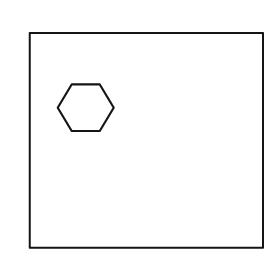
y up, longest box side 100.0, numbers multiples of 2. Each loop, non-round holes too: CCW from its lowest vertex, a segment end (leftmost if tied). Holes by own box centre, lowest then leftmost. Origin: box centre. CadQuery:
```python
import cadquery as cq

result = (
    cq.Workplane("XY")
    .moveTo(-50.0, -46.0)
    .lineTo(50.0, -46.0)
    .lineTo(50.0, 46.0)
    .lineTo(-50.0, 46.0)
    .close()
    .moveTo(-32.0, 4.0)
    .lineTo(-20.0, 4.0)
    .lineTo(-14.0, 14.0)
    .lineTo(-20.0, 24.0)
    .lineTo(-32.0, 24.0)
    .lineTo(-38.0, 14.0)
    .close()
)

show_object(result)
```